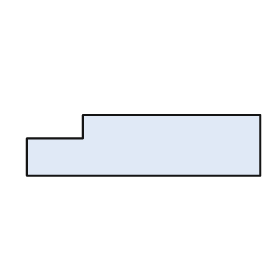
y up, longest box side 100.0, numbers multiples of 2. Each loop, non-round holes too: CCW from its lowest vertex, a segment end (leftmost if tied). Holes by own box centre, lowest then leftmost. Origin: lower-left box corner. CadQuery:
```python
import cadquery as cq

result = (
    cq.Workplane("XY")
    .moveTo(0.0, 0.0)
    .lineTo(100.0, 0.0)
    .lineTo(100.0, 26.0)
    .lineTo(24.0, 26.0)
    .lineTo(24.0, 16.0)
    .lineTo(0.0, 16.0)
    .close()
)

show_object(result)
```